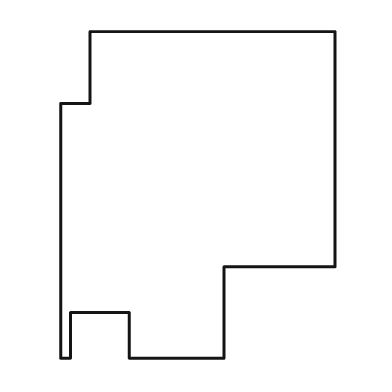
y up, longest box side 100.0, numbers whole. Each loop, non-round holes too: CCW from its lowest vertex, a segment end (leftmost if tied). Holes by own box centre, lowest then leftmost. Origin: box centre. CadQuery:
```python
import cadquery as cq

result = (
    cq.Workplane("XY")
    .moveTo(-42.0, -50.0)
    .lineTo(-39.0, -50.0)
    .lineTo(-39.0, -36.0)
    .lineTo(-21.0, -36.0)
    .lineTo(-21.0, -50.0)
    .lineTo(8.0, -50.0)
    .lineTo(8.0, -22.0)
    .lineTo(42.0, -22.0)
    .lineTo(42.0, 50.0)
    .lineTo(-33.0, 50.0)
    .lineTo(-33.0, 28.0)
    .lineTo(-42.0, 28.0)
    .close()
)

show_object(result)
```